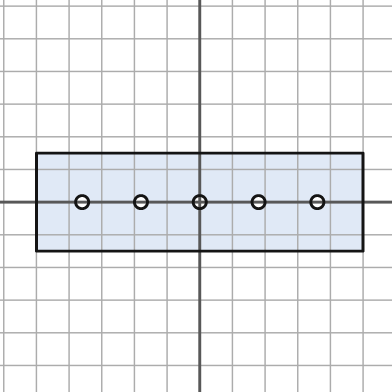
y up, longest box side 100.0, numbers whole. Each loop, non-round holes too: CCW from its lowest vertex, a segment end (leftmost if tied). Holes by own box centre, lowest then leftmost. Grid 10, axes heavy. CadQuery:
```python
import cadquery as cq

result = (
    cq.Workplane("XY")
    .moveTo(-50.0, -15.0)
    .lineTo(50.0, -15.0)
    .lineTo(50.0, 15.0)
    .lineTo(-50.0, 15.0)
    .close()
    .moveTo(-36.0, 0.0)
    .circle(2.0)
    .moveTo(-18.0, 0.0)
    .circle(2.0)
    .moveTo(0.0, 0.0)
    .circle(2.0)
    .moveTo(18.0, 0.0)
    .circle(2.0)
    .moveTo(36.0, 0.0)
    .circle(2.0)
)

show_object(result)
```